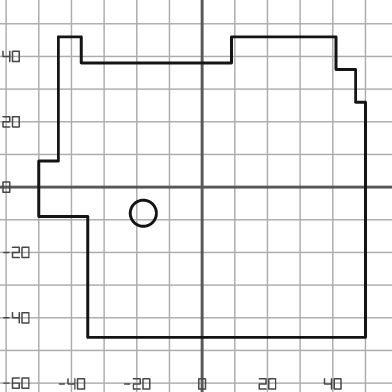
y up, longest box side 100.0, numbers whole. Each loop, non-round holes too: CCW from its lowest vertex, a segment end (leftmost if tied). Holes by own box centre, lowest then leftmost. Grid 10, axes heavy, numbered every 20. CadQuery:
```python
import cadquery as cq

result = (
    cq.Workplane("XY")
    .moveTo(-35.0, -46.0)
    .lineTo(50.0, -46.0)
    .lineTo(50.0, 26.0)
    .lineTo(47.0, 26.0)
    .lineTo(47.0, 36.0)
    .lineTo(41.0, 36.0)
    .lineTo(41.0, 46.0)
    .lineTo(9.0, 46.0)
    .lineTo(9.0, 38.0)
    .lineTo(-37.0, 38.0)
    .lineTo(-37.0, 46.0)
    .lineTo(-44.0, 46.0)
    .lineTo(-44.0, 8.0)
    .lineTo(-50.0, 8.0)
    .lineTo(-50.0, -9.0)
    .lineTo(-35.0, -9.0)
    .close()
    .moveTo(-18.0, -8.0)
    .circle(4.0)
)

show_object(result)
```